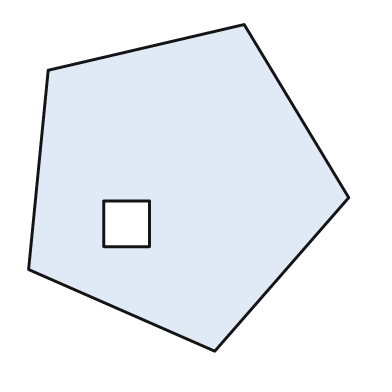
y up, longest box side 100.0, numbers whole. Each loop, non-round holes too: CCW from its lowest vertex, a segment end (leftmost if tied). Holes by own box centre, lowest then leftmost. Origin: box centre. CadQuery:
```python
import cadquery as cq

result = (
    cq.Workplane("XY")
    .moveTo(8.0, -50.0)
    .lineTo(49.0, -3.0)
    .lineTo(17.0, 50.0)
    .lineTo(-43.0, 36.0)
    .lineTo(-49.0, -25.0)
    .close()
    .moveTo(-26.0, -18.0)
    .lineTo(-12.0, -18.0)
    .lineTo(-12.0, -4.0)
    .lineTo(-26.0, -4.0)
    .close()
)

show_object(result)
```